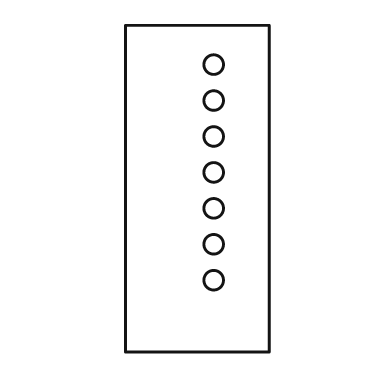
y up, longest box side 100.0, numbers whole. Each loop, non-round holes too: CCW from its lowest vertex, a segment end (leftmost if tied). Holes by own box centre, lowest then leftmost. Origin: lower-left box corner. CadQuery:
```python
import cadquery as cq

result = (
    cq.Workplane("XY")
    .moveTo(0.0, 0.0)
    .lineTo(44.0, 0.0)
    .lineTo(44.0, 100.0)
    .lineTo(0.0, 100.0)
    .close()
    .moveTo(27.0, 22.0)
    .circle(3.0)
    .moveTo(27.0, 33.0)
    .circle(3.0)
    .moveTo(27.0, 44.0)
    .circle(3.0)
    .moveTo(27.0, 55.0)
    .circle(3.0)
    .moveTo(27.0, 66.0)
    .circle(3.0)
    .moveTo(27.0, 77.0)
    .circle(3.0)
    .moveTo(27.0, 88.0)
    .circle(3.0)
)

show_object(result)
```